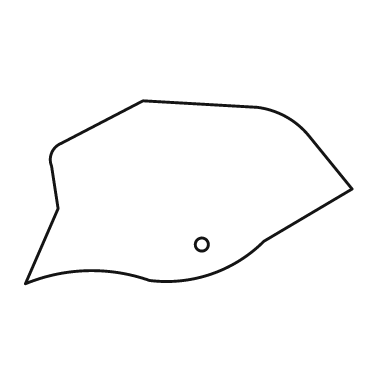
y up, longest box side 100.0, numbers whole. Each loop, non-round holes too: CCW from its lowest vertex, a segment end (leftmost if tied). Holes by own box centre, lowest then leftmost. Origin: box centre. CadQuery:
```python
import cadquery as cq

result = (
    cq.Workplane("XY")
    .moveTo(-50.0, -28.0)
    .threePointArc((-31.0, -24.0), (-12.0, -27.0))
    .threePointArc((7.0, -25.0), (23.0, -15.0))
    .lineTo(50.0, 1.0)
    .lineTo(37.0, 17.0)
    .threePointArc((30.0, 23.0), (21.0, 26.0))
    .lineTo(-14.0, 28.0)
    .lineTo(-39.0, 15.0)
    .threePointArc((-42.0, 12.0), (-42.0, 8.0))
    .lineTo(-40.0, -5.0)
    .close()
    .moveTo(4.0, -16.0)
    .circle(2.0)
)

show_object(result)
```